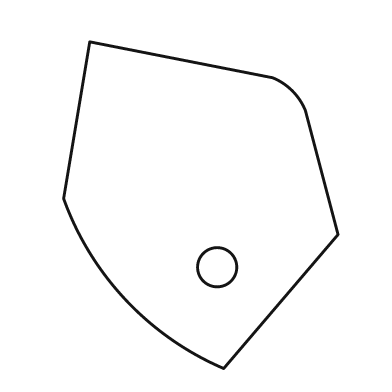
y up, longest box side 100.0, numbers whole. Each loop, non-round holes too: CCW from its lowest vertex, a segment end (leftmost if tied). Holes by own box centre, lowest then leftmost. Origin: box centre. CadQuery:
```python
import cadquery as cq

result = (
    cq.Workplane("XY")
    .moveTo(7.0, -50.0)
    .lineTo(42.0, -9.0)
    .lineTo(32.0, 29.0)
    .threePointArc((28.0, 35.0), (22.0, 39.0))
    .lineTo(-34.0, 50.0)
    .lineTo(-42.0, 2.0)
    .threePointArc((-23.0, -29.0), (7.0, -50.0))
    .close()
    .moveTo(5.0, -19.0)
    .circle(6.0)
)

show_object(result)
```